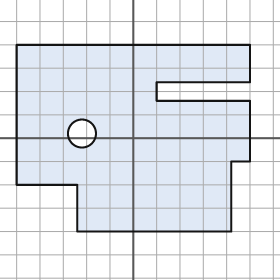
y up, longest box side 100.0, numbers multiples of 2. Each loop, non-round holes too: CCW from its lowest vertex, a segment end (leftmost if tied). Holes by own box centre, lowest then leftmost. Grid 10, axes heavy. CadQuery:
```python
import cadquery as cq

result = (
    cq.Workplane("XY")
    .moveTo(-24.0, -40.0)
    .lineTo(42.0, -40.0)
    .lineTo(42.0, -10.0)
    .lineTo(50.0, -10.0)
    .lineTo(50.0, 16.0)
    .lineTo(10.0, 16.0)
    .lineTo(10.0, 24.0)
    .lineTo(50.0, 24.0)
    .lineTo(50.0, 40.0)
    .lineTo(-50.0, 40.0)
    .lineTo(-50.0, -20.0)
    .lineTo(-24.0, -20.0)
    .close()
    .moveTo(-22.0, 2.0)
    .circle(6.0)
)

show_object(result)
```